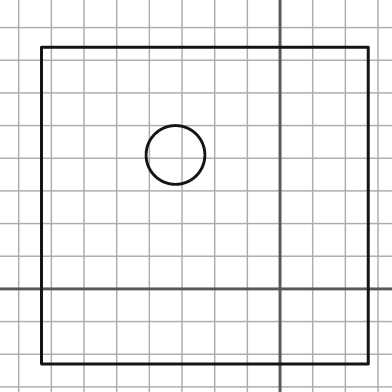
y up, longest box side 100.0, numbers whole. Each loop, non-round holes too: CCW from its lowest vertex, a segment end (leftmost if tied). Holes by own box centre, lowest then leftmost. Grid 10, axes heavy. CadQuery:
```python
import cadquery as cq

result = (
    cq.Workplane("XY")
    .moveTo(-73.0, -23.0)
    .lineTo(27.0, -23.0)
    .lineTo(27.0, 74.0)
    .lineTo(-73.0, 74.0)
    .close()
    .moveTo(-32.0, 41.0)
    .circle(9.0)
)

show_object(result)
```